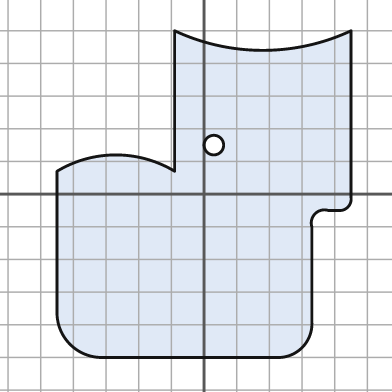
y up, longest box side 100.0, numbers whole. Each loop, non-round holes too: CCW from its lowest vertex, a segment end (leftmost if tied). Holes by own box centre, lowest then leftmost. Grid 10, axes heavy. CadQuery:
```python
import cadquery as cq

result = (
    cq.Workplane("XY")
    .moveTo(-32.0, -50.0)
    .lineTo(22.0, -50.0)
    .threePointArc((30.0, -47.0), (33.0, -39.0))
    .lineTo(33.0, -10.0)
    .threePointArc((34.0, -6.0), (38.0, -5.0))
    .lineTo(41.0, -5.0)
    .threePointArc((44.0, -4.0), (45.0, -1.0))
    .lineTo(45.0, 50.0)
    .threePointArc((18.0, 44.0), (-9.0, 50.0))
    .lineTo(-9.0, 7.0)
    .threePointArc((-27.0, 12.0), (-45.0, 7.0))
    .lineTo(-45.0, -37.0)
    .threePointArc((-41.0, -46.0), (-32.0, -50.0))
    .close()
    .moveTo(3.0, 15.0)
    .circle(3.0)
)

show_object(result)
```